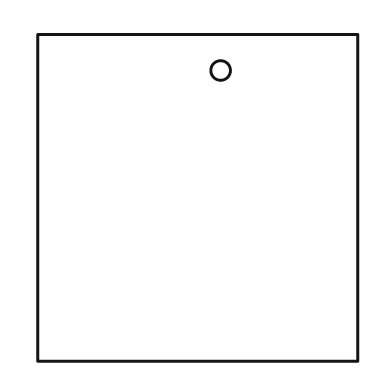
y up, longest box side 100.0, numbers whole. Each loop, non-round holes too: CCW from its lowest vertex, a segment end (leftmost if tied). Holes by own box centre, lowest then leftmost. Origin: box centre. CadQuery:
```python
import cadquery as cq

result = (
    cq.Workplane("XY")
    .moveTo(-49.0, -50.0)
    .lineTo(49.0, -50.0)
    .lineTo(49.0, 50.0)
    .lineTo(-49.0, 50.0)
    .close()
    .moveTo(7.0, 39.0)
    .circle(3.0)
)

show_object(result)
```